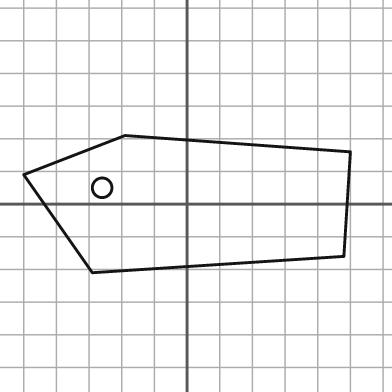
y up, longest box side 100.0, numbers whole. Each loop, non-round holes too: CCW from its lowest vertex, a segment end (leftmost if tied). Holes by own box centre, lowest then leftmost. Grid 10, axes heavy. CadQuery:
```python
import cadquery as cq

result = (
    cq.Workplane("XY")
    .moveTo(-29.0, -21.0)
    .lineTo(48.0, -16.0)
    .lineTo(50.0, 16.0)
    .lineTo(-19.0, 21.0)
    .lineTo(-50.0, 9.0)
    .close()
    .moveTo(-26.0, 5.0)
    .circle(3.0)
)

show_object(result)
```